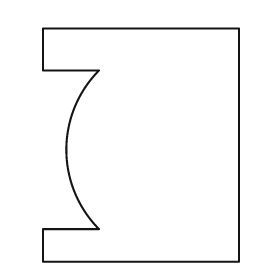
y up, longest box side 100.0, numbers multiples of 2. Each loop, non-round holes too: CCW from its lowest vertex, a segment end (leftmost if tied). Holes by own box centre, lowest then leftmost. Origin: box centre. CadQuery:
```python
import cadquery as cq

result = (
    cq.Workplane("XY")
    .moveTo(-42.0, -50.0)
    .lineTo(42.0, -50.0)
    .lineTo(42.0, 50.0)
    .lineTo(-42.0, 50.0)
    .lineTo(-42.0, 32.0)
    .lineTo(-18.0, 32.0)
    .threePointArc((-32.0, -2.0), (-18.0, -36.0))
    .lineTo(-42.0, -36.0)
    .close()
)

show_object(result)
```